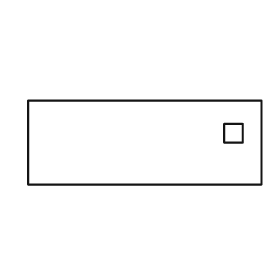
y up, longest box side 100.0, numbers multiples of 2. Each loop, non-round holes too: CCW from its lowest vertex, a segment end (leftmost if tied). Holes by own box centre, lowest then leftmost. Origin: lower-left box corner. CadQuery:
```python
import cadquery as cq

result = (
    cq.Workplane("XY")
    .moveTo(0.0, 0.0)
    .lineTo(100.0, 0.0)
    .lineTo(100.0, 36.0)
    .lineTo(0.0, 36.0)
    .close()
    .moveTo(84.0, 18.0)
    .lineTo(92.0, 18.0)
    .lineTo(92.0, 26.0)
    .lineTo(84.0, 26.0)
    .close()
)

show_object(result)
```